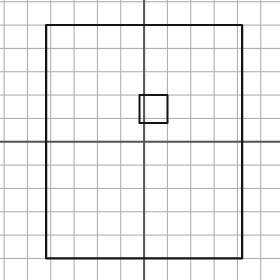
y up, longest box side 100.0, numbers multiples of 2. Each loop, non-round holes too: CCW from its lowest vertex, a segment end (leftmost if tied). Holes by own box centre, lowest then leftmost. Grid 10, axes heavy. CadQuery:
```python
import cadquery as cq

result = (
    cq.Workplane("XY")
    .moveTo(-42.0, -50.0)
    .lineTo(42.0, -50.0)
    .lineTo(42.0, 50.0)
    .lineTo(-42.0, 50.0)
    .close()
    .moveTo(-2.0, 8.0)
    .lineTo(10.0, 8.0)
    .lineTo(10.0, 20.0)
    .lineTo(-2.0, 20.0)
    .close()
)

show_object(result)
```